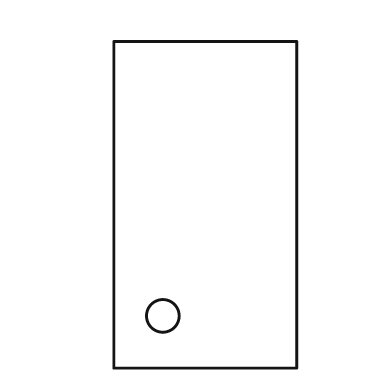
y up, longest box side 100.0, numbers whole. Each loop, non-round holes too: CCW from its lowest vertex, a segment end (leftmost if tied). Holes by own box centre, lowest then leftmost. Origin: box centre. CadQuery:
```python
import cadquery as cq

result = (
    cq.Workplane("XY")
    .moveTo(-28.0, -50.0)
    .lineTo(28.0, -50.0)
    .lineTo(28.0, 50.0)
    .lineTo(-28.0, 50.0)
    .close()
    .moveTo(-13.0, -34.0)
    .circle(5.0)
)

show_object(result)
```